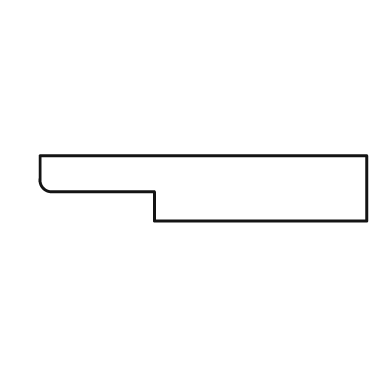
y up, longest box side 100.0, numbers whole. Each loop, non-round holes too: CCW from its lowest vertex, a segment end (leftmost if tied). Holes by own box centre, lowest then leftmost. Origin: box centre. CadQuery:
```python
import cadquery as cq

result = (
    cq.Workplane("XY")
    .moveTo(-15.0, -10.0)
    .lineTo(50.0, -10.0)
    .lineTo(50.0, 10.0)
    .lineTo(-50.0, 10.0)
    .lineTo(-50.0, 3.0)
    .threePointArc((-49.0, 0.0), (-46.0, -1.0))
    .lineTo(-15.0, -1.0)
    .close()
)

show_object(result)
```